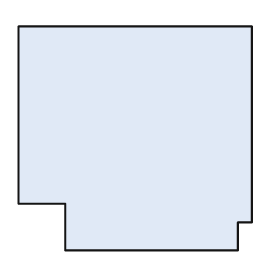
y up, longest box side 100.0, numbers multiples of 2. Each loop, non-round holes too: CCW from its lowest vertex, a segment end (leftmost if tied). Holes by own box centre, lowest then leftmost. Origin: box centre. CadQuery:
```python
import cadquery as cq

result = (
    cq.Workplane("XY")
    .moveTo(-30.0, -48.0)
    .lineTo(44.0, -48.0)
    .lineTo(44.0, -36.0)
    .lineTo(50.0, -36.0)
    .lineTo(50.0, 48.0)
    .lineTo(-50.0, 48.0)
    .lineTo(-50.0, -28.0)
    .lineTo(-30.0, -28.0)
    .close()
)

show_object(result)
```